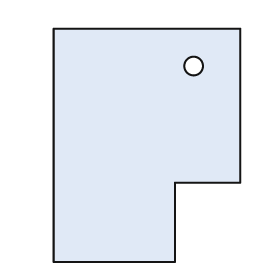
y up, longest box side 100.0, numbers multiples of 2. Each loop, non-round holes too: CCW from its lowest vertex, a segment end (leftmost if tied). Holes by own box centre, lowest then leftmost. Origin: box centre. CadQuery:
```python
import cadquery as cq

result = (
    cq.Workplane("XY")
    .moveTo(-40.0, -50.0)
    .lineTo(12.0, -50.0)
    .lineTo(12.0, -16.0)
    .lineTo(40.0, -16.0)
    .lineTo(40.0, 50.0)
    .lineTo(-40.0, 50.0)
    .close()
    .moveTo(20.0, 34.0)
    .circle(4.0)
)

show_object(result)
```